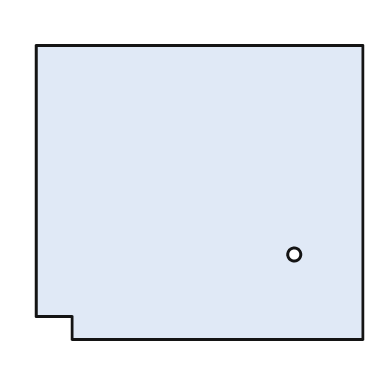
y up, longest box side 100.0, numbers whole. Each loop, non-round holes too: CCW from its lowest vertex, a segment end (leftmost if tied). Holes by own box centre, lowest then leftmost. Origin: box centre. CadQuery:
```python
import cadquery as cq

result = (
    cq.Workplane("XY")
    .moveTo(-39.0, -45.0)
    .lineTo(50.0, -45.0)
    .lineTo(50.0, 45.0)
    .lineTo(-50.0, 45.0)
    .lineTo(-50.0, -38.0)
    .lineTo(-39.0, -38.0)
    .close()
    .moveTo(29.0, -19.0)
    .circle(2.0)
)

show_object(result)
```